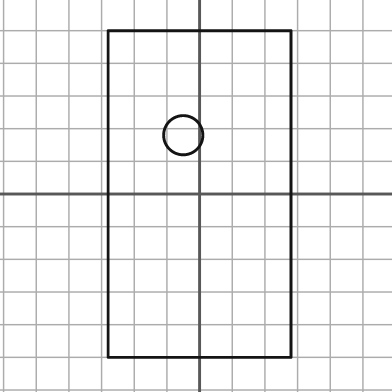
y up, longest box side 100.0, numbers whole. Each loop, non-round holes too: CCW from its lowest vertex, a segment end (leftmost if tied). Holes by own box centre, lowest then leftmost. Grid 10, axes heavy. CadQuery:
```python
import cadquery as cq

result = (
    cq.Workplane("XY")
    .moveTo(-28.0, -50.0)
    .lineTo(28.0, -50.0)
    .lineTo(28.0, 50.0)
    .lineTo(-28.0, 50.0)
    .close()
    .moveTo(-5.0, 18.0)
    .circle(6.0)
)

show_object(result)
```